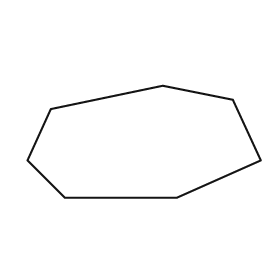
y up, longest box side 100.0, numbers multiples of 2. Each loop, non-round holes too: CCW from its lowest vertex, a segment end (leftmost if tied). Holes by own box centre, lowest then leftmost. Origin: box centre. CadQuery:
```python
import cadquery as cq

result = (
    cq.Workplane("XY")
    .moveTo(-34.0, -24.0)
    .lineTo(14.0, -24.0)
    .lineTo(50.0, -8.0)
    .lineTo(38.0, 18.0)
    .lineTo(8.0, 24.0)
    .lineTo(-40.0, 14.0)
    .lineTo(-50.0, -8.0)
    .close()
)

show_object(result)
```